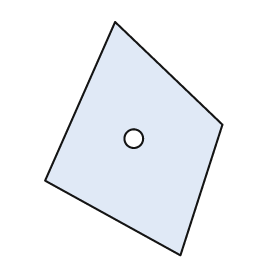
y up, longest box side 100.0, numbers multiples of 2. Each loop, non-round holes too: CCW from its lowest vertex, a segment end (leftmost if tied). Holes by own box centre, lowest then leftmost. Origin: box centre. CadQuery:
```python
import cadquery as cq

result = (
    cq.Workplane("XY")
    .moveTo(20.0, -50.0)
    .lineTo(38.0, 6.0)
    .lineTo(-8.0, 50.0)
    .lineTo(-38.0, -18.0)
    .close()
    .moveTo(0.0, 0.0)
    .circle(4.0)
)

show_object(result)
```